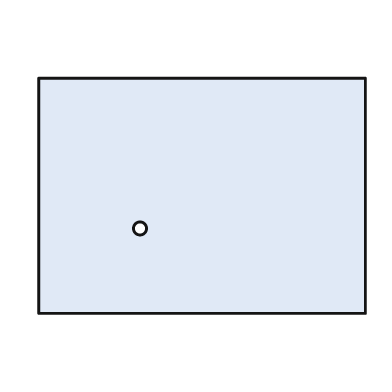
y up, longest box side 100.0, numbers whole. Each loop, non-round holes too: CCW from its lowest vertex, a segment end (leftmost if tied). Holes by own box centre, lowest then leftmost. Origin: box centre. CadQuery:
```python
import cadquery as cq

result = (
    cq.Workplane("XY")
    .moveTo(-50.0, -36.0)
    .lineTo(50.0, -36.0)
    .lineTo(50.0, 36.0)
    .lineTo(-50.0, 36.0)
    .close()
    .moveTo(-19.0, -10.0)
    .circle(2.0)
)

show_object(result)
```